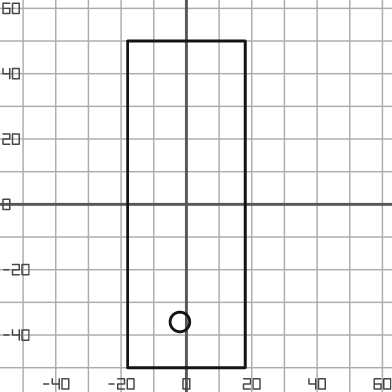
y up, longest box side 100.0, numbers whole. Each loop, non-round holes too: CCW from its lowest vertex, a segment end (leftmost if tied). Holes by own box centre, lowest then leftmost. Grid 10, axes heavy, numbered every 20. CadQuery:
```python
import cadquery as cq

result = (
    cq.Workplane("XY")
    .moveTo(-18.0, -50.0)
    .lineTo(18.0, -50.0)
    .lineTo(18.0, 50.0)
    .lineTo(-18.0, 50.0)
    .close()
    .moveTo(-2.0, -36.0)
    .circle(3.0)
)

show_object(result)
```